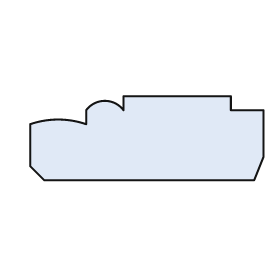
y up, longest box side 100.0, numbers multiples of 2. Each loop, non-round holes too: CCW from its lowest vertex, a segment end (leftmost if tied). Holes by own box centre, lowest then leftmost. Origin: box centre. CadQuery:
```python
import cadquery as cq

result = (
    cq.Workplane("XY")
    .moveTo(-44.0, -18.0)
    .lineTo(46.0, -18.0)
    .lineTo(50.0, -8.0)
    .lineTo(50.0, 12.0)
    .lineTo(36.0, 12.0)
    .lineTo(36.0, 18.0)
    .lineTo(-10.0, 18.0)
    .lineTo(-10.0, 12.0)
    .threePointArc((-18.0, 16.0), (-26.0, 12.0))
    .lineTo(-26.0, 6.0)
    .threePointArc((-38.0, 8.0), (-50.0, 6.0))
    .lineTo(-50.0, -12.0)
    .close()
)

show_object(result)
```